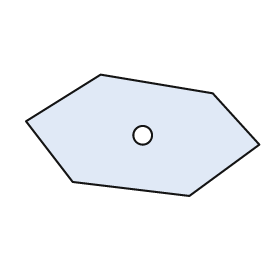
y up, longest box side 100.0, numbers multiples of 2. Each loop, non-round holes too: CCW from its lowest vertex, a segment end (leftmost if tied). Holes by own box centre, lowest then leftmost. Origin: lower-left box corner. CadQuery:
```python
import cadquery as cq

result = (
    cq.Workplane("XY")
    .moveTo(70.0, 0.0)
    .lineTo(100.0, 22.0)
    .lineTo(80.0, 44.0)
    .lineTo(32.0, 52.0)
    .lineTo(0.0, 32.0)
    .lineTo(20.0, 6.0)
    .close()
    .moveTo(50.0, 26.0)
    .circle(4.0)
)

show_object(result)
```